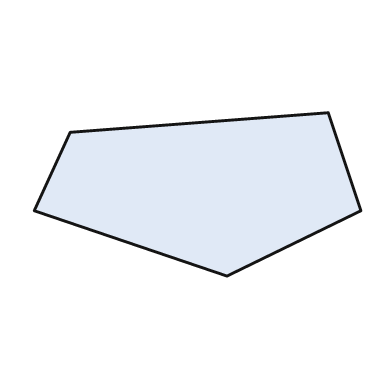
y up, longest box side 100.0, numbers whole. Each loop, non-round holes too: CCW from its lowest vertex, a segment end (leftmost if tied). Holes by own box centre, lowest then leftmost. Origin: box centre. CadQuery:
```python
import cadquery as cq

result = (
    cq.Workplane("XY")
    .moveTo(9.0, -25.0)
    .lineTo(50.0, -5.0)
    .lineTo(40.0, 25.0)
    .lineTo(-39.0, 19.0)
    .lineTo(-50.0, -5.0)
    .close()
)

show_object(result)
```